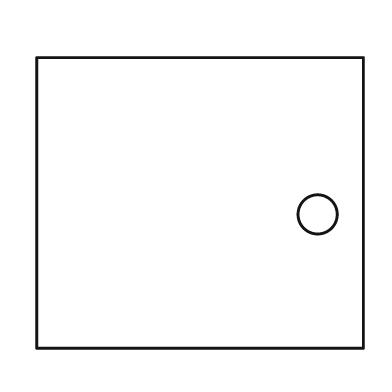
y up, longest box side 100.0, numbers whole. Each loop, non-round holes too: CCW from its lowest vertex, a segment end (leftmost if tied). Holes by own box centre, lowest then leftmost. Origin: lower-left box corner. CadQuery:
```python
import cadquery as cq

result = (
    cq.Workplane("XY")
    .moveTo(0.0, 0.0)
    .lineTo(100.0, 0.0)
    .lineTo(100.0, 89.0)
    .lineTo(0.0, 89.0)
    .close()
    .moveTo(86.0, 41.0)
    .circle(6.0)
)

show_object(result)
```